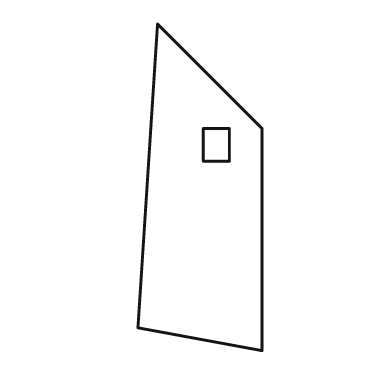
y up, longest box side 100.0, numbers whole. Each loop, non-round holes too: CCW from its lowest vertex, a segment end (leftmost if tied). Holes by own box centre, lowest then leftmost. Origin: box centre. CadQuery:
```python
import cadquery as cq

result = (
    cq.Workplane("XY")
    .moveTo(19.0, -50.0)
    .lineTo(19.0, 18.0)
    .lineTo(-13.0, 50.0)
    .lineTo(-19.0, -43.0)
    .close()
    .moveTo(1.0, 8.0)
    .lineTo(9.0, 8.0)
    .lineTo(9.0, 18.0)
    .lineTo(1.0, 18.0)
    .close()
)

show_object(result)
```